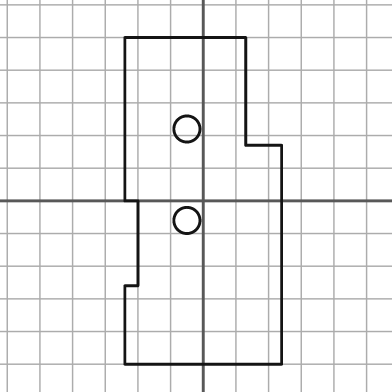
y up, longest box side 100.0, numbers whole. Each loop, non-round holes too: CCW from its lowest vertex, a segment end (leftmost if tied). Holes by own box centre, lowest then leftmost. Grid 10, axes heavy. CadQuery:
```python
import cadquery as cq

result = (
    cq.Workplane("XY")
    .moveTo(-24.0, -50.0)
    .lineTo(24.0, -50.0)
    .lineTo(24.0, 17.0)
    .lineTo(13.0, 17.0)
    .lineTo(13.0, 50.0)
    .lineTo(-24.0, 50.0)
    .lineTo(-24.0, 0.0)
    .lineTo(-20.0, 0.0)
    .lineTo(-20.0, -26.0)
    .lineTo(-24.0, -26.0)
    .close()
    .moveTo(-5.0, -6.0)
    .circle(4.0)
    .moveTo(-5.0, 22.0)
    .circle(4.0)
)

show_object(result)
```